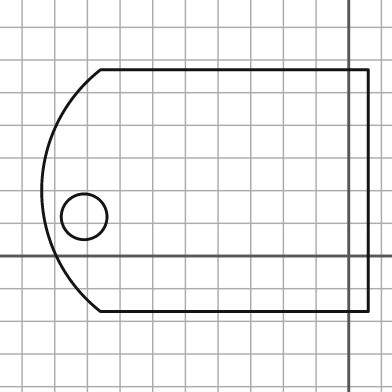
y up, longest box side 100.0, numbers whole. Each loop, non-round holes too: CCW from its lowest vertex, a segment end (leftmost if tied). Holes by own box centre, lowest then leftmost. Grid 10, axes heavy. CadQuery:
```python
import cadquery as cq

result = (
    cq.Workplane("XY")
    .moveTo(-76.0, -17.0)
    .lineTo(6.0, -17.0)
    .lineTo(6.0, 57.0)
    .lineTo(-76.0, 57.0)
    .threePointArc((-94.0, 20.0), (-76.0, -17.0))
    .close()
    .moveTo(-81.0, 12.0)
    .circle(7.0)
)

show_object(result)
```